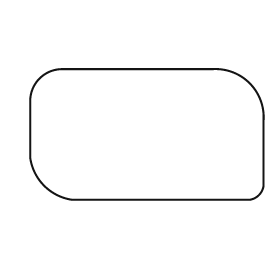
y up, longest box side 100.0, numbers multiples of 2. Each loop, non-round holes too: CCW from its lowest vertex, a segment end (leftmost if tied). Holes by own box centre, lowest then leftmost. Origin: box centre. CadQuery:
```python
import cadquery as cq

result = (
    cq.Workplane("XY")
    .moveTo(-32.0, -28.0)
    .lineTo(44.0, -28.0)
    .threePointArc((48.0, -26.0), (50.0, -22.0))
    .lineTo(50.0, 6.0)
    .threePointArc((44.0, 22.0), (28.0, 28.0))
    .lineTo(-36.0, 28.0)
    .threePointArc((-46.0, 24.0), (-50.0, 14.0))
    .lineTo(-50.0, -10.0)
    .threePointArc((-44.0, -22.0), (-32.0, -28.0))
    .close()
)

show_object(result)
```